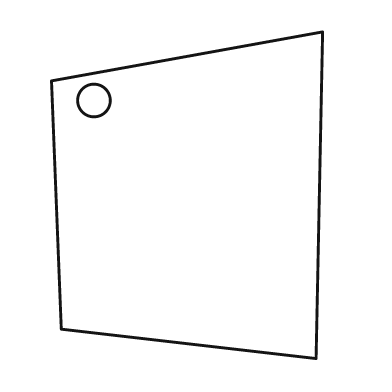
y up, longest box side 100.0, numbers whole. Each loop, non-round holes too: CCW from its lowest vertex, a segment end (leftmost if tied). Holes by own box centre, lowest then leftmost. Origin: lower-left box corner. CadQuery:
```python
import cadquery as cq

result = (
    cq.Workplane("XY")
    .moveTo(81.0, 0.0)
    .lineTo(83.0, 100.0)
    .lineTo(0.0, 85.0)
    .lineTo(3.0, 9.0)
    .close()
    .moveTo(13.0, 79.0)
    .circle(5.0)
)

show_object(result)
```